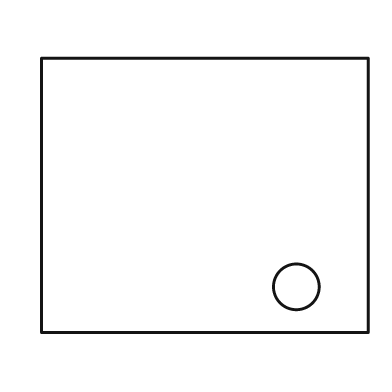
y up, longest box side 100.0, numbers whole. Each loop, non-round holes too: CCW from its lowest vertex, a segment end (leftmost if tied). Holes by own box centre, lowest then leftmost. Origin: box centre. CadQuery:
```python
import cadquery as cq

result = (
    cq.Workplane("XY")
    .moveTo(-50.0, -42.0)
    .lineTo(50.0, -42.0)
    .lineTo(50.0, 42.0)
    .lineTo(-50.0, 42.0)
    .close()
    .moveTo(28.0, -28.0)
    .circle(7.0)
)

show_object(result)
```